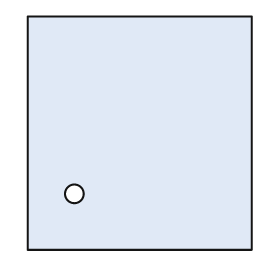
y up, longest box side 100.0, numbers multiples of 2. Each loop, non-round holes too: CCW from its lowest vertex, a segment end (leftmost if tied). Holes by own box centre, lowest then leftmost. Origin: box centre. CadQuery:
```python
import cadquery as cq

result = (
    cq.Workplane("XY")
    .moveTo(-48.0, -50.0)
    .lineTo(48.0, -50.0)
    .lineTo(48.0, 50.0)
    .lineTo(-48.0, 50.0)
    .close()
    .moveTo(-28.0, -26.0)
    .circle(4.0)
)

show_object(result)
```